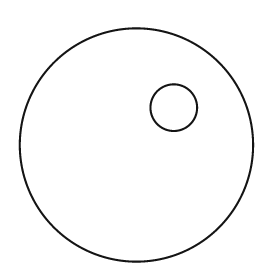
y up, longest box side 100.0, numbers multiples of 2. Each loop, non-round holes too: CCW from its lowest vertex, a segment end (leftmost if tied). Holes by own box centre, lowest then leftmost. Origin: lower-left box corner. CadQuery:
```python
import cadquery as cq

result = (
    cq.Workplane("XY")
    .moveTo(50.0, 50.0)
    .circle(50.0)
    .moveTo(66.0, 66.0)
    .circle(10.0)
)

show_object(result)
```